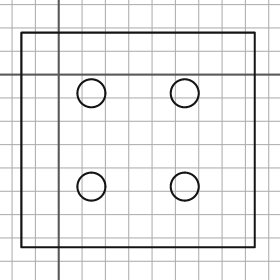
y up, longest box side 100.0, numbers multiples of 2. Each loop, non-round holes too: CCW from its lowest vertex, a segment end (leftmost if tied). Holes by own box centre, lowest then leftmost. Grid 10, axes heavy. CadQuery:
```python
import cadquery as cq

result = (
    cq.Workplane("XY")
    .moveTo(-16.0, -74.0)
    .lineTo(84.0, -74.0)
    .lineTo(84.0, 18.0)
    .lineTo(-16.0, 18.0)
    .close()
    .moveTo(14.0, -48.0)
    .circle(6.0)
    .moveTo(54.0, -48.0)
    .circle(6.0)
    .moveTo(14.0, -8.0)
    .circle(6.0)
    .moveTo(54.0, -8.0)
    .circle(6.0)
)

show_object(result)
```